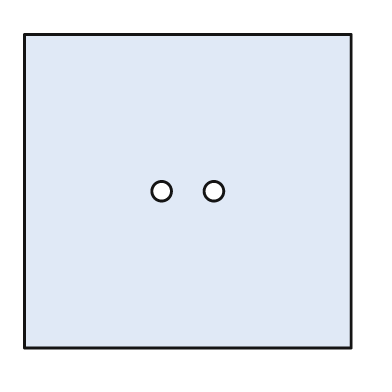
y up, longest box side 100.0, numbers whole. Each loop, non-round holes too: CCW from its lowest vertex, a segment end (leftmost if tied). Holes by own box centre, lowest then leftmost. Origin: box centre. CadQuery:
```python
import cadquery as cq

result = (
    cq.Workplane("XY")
    .moveTo(-50.0, -48.0)
    .lineTo(50.0, -48.0)
    .lineTo(50.0, 48.0)
    .lineTo(-50.0, 48.0)
    .close()
    .moveTo(-8.0, 0.0)
    .circle(3.0)
    .moveTo(8.0, 0.0)
    .circle(3.0)
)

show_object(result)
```